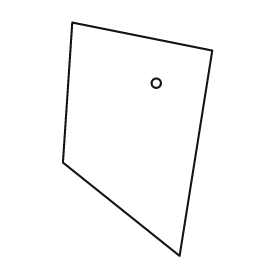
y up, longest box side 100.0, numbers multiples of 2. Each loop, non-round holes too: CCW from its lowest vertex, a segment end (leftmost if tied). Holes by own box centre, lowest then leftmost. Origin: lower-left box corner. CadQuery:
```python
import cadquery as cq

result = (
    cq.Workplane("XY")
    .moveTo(50.0, 0.0)
    .lineTo(64.0, 88.0)
    .lineTo(4.0, 100.0)
    .lineTo(0.0, 40.0)
    .close()
    .moveTo(40.0, 74.0)
    .circle(2.0)
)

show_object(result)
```